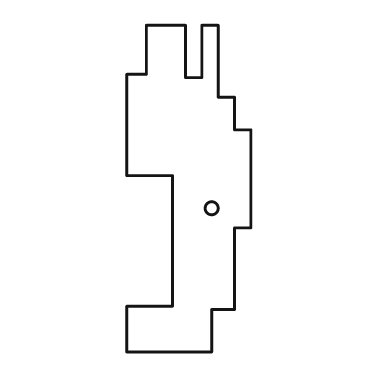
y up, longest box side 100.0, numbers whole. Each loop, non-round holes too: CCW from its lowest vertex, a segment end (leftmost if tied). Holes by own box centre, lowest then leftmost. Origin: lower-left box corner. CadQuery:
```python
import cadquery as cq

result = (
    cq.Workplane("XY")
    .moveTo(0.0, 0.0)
    .lineTo(26.0, 0.0)
    .lineTo(26.0, 13.0)
    .lineTo(33.0, 13.0)
    .lineTo(33.0, 38.0)
    .lineTo(38.0, 38.0)
    .lineTo(38.0, 68.0)
    .lineTo(33.0, 68.0)
    .lineTo(33.0, 78.0)
    .lineTo(28.0, 78.0)
    .lineTo(28.0, 100.0)
    .lineTo(23.0, 100.0)
    .lineTo(23.0, 84.0)
    .lineTo(18.0, 84.0)
    .lineTo(18.0, 100.0)
    .lineTo(6.0, 100.0)
    .lineTo(6.0, 85.0)
    .lineTo(0.0, 85.0)
    .lineTo(0.0, 54.0)
    .lineTo(14.0, 54.0)
    .lineTo(14.0, 14.0)
    .lineTo(0.0, 14.0)
    .close()
    .moveTo(26.0, 44.0)
    .circle(2.0)
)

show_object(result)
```